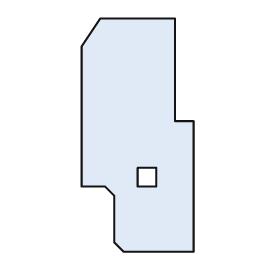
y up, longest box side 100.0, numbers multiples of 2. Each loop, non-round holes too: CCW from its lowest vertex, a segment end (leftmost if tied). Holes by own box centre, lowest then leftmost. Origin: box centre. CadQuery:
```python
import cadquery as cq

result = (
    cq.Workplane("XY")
    .moveTo(-6.0, -50.0)
    .lineTo(24.0, -50.0)
    .lineTo(24.0, 6.0)
    .lineTo(16.0, 6.0)
    .lineTo(16.0, 50.0)
    .lineTo(-16.0, 50.0)
    .lineTo(-24.0, 38.0)
    .lineTo(-24.0, -22.0)
    .lineTo(-14.0, -22.0)
    .lineTo(-10.0, -26.0)
    .lineTo(-10.0, -46.0)
    .close()
    .moveTo(0.0, -22.0)
    .lineTo(8.0, -22.0)
    .lineTo(8.0, -14.0)
    .lineTo(0.0, -14.0)
    .close()
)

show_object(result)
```